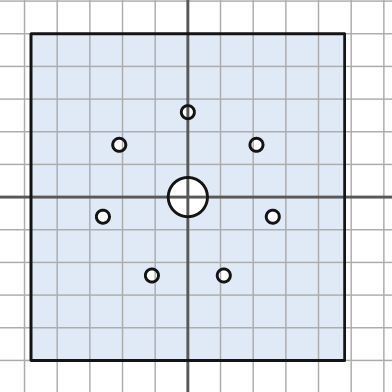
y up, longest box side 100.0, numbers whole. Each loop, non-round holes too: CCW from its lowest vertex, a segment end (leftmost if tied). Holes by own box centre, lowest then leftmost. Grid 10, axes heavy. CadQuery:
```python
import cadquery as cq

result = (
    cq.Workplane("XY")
    .moveTo(-48.0, -50.0)
    .lineTo(48.0, -50.0)
    .lineTo(48.0, 50.0)
    .lineTo(-48.0, 50.0)
    .close()
    .moveTo(-11.0, -24.0)
    .circle(2.0)
    .moveTo(11.0, -24.0)
    .circle(2.0)
    .moveTo(-26.0, -6.0)
    .circle(2.0)
    .moveTo(26.0, -6.0)
    .circle(2.0)
    .moveTo(0.0, 0.0)
    .circle(6.0)
    .moveTo(-21.0, 16.0)
    .circle(2.0)
    .moveTo(21.0, 16.0)
    .circle(2.0)
    .moveTo(0.0, 26.0)
    .circle(2.0)
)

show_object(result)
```